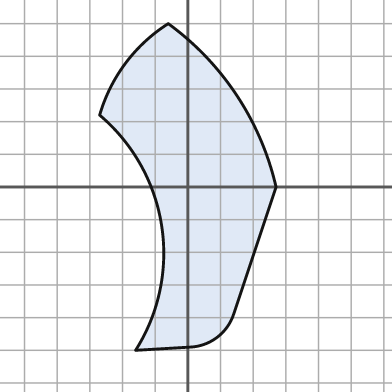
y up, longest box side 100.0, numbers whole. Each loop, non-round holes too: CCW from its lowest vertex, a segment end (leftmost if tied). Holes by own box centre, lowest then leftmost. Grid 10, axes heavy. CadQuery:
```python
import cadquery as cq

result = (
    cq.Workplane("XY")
    .moveTo(-16.0, -50.0)
    .lineTo(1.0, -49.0)
    .threePointArc((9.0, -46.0), (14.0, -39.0))
    .lineTo(27.0, 0.0)
    .threePointArc((15.0, 28.0), (-6.0, 50.0))
    .threePointArc((-19.0, 38.0), (-27.0, 22.0))
    .threePointArc((-8.0, -12.0), (-16.0, -50.0))
    .close()
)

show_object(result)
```